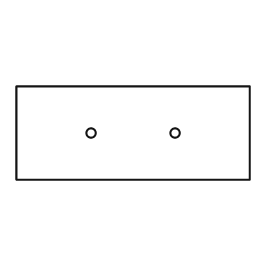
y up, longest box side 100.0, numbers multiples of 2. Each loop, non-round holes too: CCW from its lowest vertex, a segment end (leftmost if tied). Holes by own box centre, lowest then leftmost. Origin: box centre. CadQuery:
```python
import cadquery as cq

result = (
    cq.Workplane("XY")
    .moveTo(-50.0, -20.0)
    .lineTo(50.0, -20.0)
    .lineTo(50.0, 20.0)
    .lineTo(-50.0, 20.0)
    .close()
    .moveTo(-18.0, 0.0)
    .circle(2.0)
    .moveTo(18.0, 0.0)
    .circle(2.0)
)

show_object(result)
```